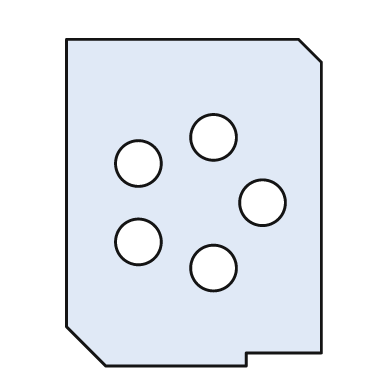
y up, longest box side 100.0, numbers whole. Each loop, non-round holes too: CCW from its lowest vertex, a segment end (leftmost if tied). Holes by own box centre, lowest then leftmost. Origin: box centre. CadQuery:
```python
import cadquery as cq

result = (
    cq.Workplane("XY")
    .moveTo(-27.0, -50.0)
    .lineTo(16.0, -50.0)
    .lineTo(16.0, -46.0)
    .lineTo(39.0, -46.0)
    .lineTo(39.0, 43.0)
    .lineTo(32.0, 50.0)
    .lineTo(-39.0, 50.0)
    .lineTo(-39.0, -38.0)
    .close()
    .moveTo(6.0, -20.0)
    .circle(7.0)
    .moveTo(-17.0, -12.0)
    .circle(7.0)
    .moveTo(21.0, 0.0)
    .circle(7.0)
    .moveTo(-17.0, 12.0)
    .circle(7.0)
    .moveTo(6.0, 20.0)
    .circle(7.0)
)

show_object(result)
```